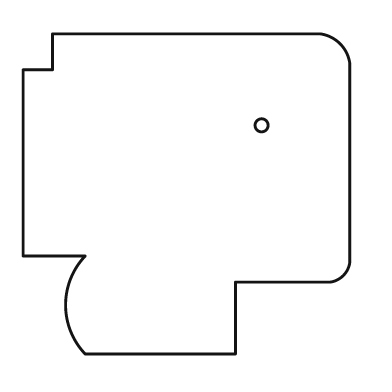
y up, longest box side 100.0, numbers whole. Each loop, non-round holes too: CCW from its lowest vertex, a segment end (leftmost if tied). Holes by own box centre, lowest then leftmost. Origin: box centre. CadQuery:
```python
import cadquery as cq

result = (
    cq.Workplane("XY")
    .moveTo(-31.0, -49.0)
    .lineTo(15.0, -49.0)
    .lineTo(15.0, -27.0)
    .lineTo(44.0, -27.0)
    .threePointArc((48.0, -25.0), (50.0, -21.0))
    .lineTo(50.0, 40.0)
    .threePointArc((47.0, 46.0), (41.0, 49.0))
    .lineTo(-41.0, 49.0)
    .lineTo(-41.0, 38.0)
    .lineTo(-50.0, 38.0)
    .lineTo(-50.0, -19.0)
    .lineTo(-31.0, -19.0)
    .threePointArc((-37.0, -34.0), (-31.0, -49.0))
    .close()
    .moveTo(23.0, 21.0)
    .circle(2.0)
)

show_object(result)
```